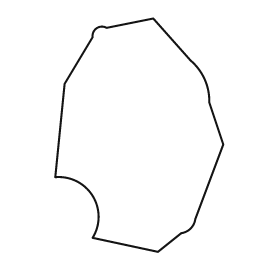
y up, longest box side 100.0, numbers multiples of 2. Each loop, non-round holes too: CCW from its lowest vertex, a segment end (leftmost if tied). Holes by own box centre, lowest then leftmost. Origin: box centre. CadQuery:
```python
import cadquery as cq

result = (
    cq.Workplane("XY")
    .moveTo(8.0, -50.0)
    .lineTo(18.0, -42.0)
    .threePointArc((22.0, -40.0), (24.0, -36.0))
    .lineTo(36.0, -4.0)
    .lineTo(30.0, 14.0)
    .threePointArc((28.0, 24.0), (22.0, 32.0))
    .lineTo(6.0, 50.0)
    .lineTo(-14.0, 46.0)
    .threePointArc((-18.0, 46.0), (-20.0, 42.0))
    .lineTo(-32.0, 22.0)
    .lineTo(-36.0, -18.0)
    .threePointArc((-20.0, -26.0), (-20.0, -44.0))
    .close()
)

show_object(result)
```